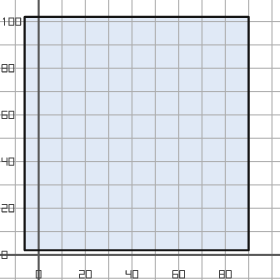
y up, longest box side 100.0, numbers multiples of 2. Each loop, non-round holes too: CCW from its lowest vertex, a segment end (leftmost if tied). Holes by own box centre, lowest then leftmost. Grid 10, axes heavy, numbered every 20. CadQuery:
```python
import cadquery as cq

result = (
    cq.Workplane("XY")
    .moveTo(-6.0, 2.0)
    .lineTo(90.0, 2.0)
    .lineTo(90.0, 102.0)
    .lineTo(-6.0, 102.0)
    .close()
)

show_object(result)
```